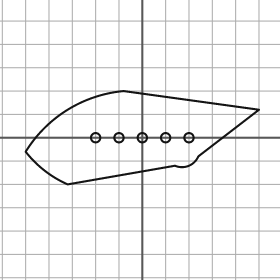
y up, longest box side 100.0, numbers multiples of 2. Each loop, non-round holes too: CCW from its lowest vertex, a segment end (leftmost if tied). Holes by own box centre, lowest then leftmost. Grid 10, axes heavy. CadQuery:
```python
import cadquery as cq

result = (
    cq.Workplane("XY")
    .moveTo(-32.0, -20.0)
    .lineTo(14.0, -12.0)
    .threePointArc((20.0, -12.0), (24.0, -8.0))
    .lineTo(50.0, 12.0)
    .lineTo(-8.0, 20.0)
    .threePointArc((-32.0, 12.0), (-50.0, -6.0))
    .threePointArc((-42.0, -14.0), (-32.0, -20.0))
    .close()
    .moveTo(-20.0, 0.0)
    .circle(2.0)
    .moveTo(-10.0, 0.0)
    .circle(2.0)
    .moveTo(0.0, 0.0)
    .circle(2.0)
    .moveTo(10.0, 0.0)
    .circle(2.0)
    .moveTo(20.0, 0.0)
    .circle(2.0)
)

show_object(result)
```